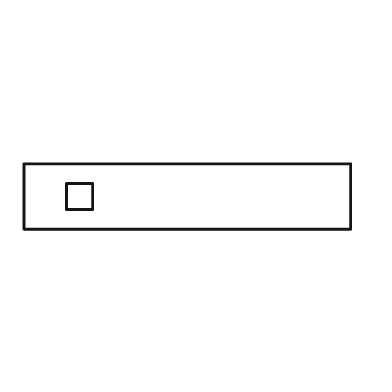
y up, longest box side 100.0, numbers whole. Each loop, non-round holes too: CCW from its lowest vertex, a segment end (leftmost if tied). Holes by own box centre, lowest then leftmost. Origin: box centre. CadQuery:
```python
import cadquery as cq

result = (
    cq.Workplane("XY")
    .moveTo(-50.0, -10.0)
    .lineTo(50.0, -10.0)
    .lineTo(50.0, 10.0)
    .lineTo(-50.0, 10.0)
    .close()
    .moveTo(-37.0, -4.0)
    .lineTo(-29.0, -4.0)
    .lineTo(-29.0, 4.0)
    .lineTo(-37.0, 4.0)
    .close()
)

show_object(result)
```